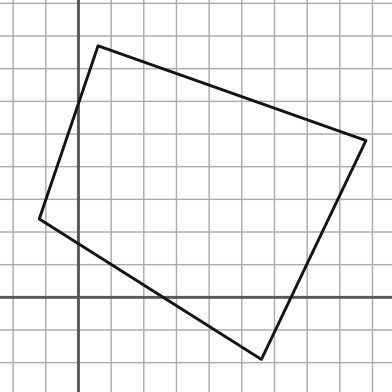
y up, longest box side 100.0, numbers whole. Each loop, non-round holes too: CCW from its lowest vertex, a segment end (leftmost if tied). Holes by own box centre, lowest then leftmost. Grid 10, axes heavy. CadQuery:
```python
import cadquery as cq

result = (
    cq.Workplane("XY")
    .moveTo(56.0, -19.0)
    .lineTo(88.0, 48.0)
    .lineTo(6.0, 77.0)
    .lineTo(-12.0, 24.0)
    .close()
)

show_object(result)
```